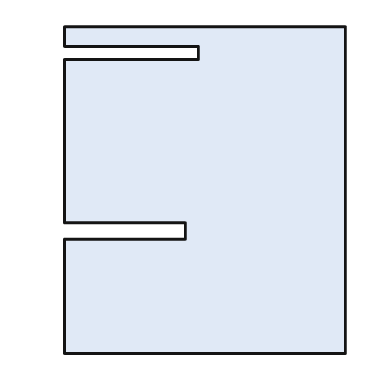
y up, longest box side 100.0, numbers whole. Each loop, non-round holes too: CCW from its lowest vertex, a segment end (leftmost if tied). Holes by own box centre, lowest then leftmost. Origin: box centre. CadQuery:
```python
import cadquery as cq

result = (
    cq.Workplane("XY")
    .moveTo(-43.0, -50.0)
    .lineTo(43.0, -50.0)
    .lineTo(43.0, 50.0)
    .lineTo(-43.0, 50.0)
    .lineTo(-43.0, 44.0)
    .lineTo(-2.0, 44.0)
    .lineTo(-2.0, 40.0)
    .lineTo(-43.0, 40.0)
    .lineTo(-43.0, -10.0)
    .lineTo(-6.0, -10.0)
    .lineTo(-6.0, -15.0)
    .lineTo(-43.0, -15.0)
    .close()
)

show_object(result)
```